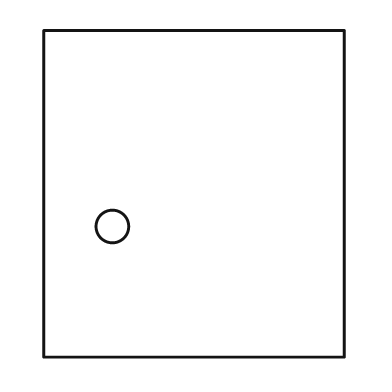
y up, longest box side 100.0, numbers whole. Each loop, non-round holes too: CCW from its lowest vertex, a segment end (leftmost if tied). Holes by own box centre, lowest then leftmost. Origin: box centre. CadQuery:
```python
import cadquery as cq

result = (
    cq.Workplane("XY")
    .moveTo(-46.0, -50.0)
    .lineTo(46.0, -50.0)
    .lineTo(46.0, 50.0)
    .lineTo(-46.0, 50.0)
    .close()
    .moveTo(-25.0, -10.0)
    .circle(5.0)
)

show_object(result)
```